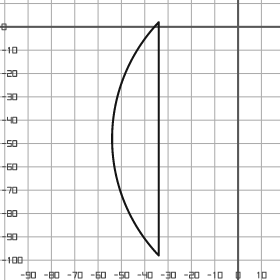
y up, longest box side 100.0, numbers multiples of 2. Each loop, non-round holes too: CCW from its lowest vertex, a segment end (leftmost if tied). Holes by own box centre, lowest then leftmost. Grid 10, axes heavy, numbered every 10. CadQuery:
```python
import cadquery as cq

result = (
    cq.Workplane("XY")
    .moveTo(-34.0, -98.0)
    .lineTo(-34.0, 2.0)
    .threePointArc((-54.0, -48.0), (-34.0, -98.0))
    .close()
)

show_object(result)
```